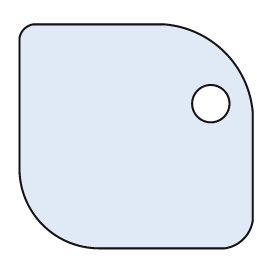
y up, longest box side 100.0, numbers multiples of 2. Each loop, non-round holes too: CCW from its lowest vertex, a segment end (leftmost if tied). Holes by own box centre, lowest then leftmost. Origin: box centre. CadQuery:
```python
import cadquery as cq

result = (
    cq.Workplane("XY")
    .moveTo(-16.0, -48.0)
    .lineTo(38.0, -48.0)
    .threePointArc((46.0, -44.0), (50.0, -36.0))
    .lineTo(50.0, 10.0)
    .threePointArc((38.0, 36.0), (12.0, 48.0))
    .lineTo(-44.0, 48.0)
    .threePointArc((-48.0, 46.0), (-50.0, 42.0))
    .lineTo(-50.0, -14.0)
    .threePointArc((-40.0, -38.0), (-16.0, -48.0))
    .close()
    .moveTo(32.0, 14.0)
    .circle(8.0)
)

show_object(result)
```